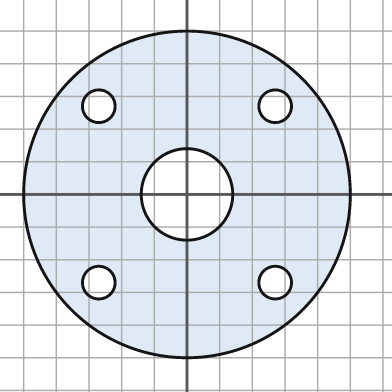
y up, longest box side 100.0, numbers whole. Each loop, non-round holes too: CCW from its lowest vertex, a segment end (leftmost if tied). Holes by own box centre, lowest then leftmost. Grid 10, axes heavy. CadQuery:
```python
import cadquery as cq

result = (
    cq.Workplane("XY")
    .moveTo(0.0, 0.0)
    .circle(50.0)
    .moveTo(-27.0, -27.0)
    .circle(5.0)
    .moveTo(27.0, -27.0)
    .circle(5.0)
    .moveTo(0.0, 0.0)
    .circle(14.0)
    .moveTo(-27.0, 27.0)
    .circle(5.0)
    .moveTo(27.0, 27.0)
    .circle(5.0)
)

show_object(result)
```